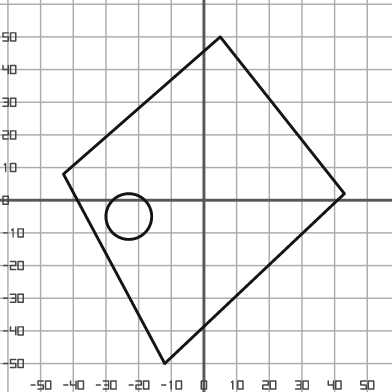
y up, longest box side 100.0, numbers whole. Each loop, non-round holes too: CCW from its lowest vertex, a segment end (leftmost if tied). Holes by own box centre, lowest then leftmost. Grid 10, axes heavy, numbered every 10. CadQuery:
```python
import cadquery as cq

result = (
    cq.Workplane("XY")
    .moveTo(-12.0, -50.0)
    .lineTo(43.0, 2.0)
    .lineTo(5.0, 50.0)
    .lineTo(-43.0, 8.0)
    .close()
    .moveTo(-23.0, -5.0)
    .circle(7.0)
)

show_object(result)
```